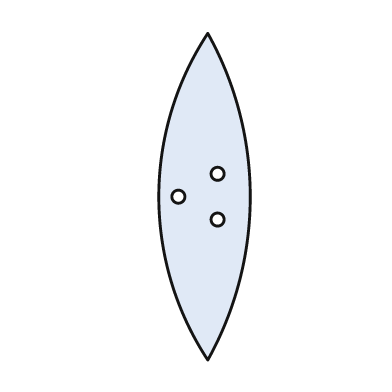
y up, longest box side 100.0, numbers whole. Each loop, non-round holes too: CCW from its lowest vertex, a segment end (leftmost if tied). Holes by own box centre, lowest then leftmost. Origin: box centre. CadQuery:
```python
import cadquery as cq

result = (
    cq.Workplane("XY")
    .moveTo(1.0, -50.0)
    .threePointArc((14.0, 0.0), (1.0, 50.0))
    .threePointArc((-14.0, 0.0), (1.0, -50.0))
    .close()
    .moveTo(4.0, -7.0)
    .circle(2.0)
    .moveTo(-8.0, 0.0)
    .circle(2.0)
    .moveTo(4.0, 7.0)
    .circle(2.0)
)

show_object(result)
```